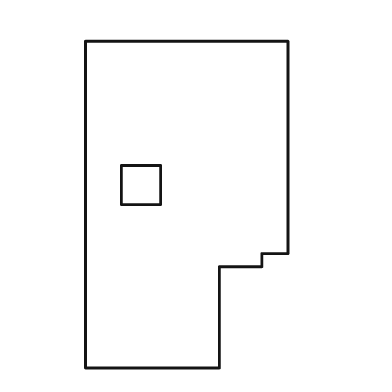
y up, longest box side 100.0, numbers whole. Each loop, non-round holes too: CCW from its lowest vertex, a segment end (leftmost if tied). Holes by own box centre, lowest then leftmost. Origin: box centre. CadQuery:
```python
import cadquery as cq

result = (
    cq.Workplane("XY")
    .moveTo(-31.0, -50.0)
    .lineTo(10.0, -50.0)
    .lineTo(10.0, -19.0)
    .lineTo(23.0, -19.0)
    .lineTo(23.0, -15.0)
    .lineTo(31.0, -15.0)
    .lineTo(31.0, 50.0)
    .lineTo(-31.0, 50.0)
    .close()
    .moveTo(-20.0, 0.0)
    .lineTo(-8.0, 0.0)
    .lineTo(-8.0, 12.0)
    .lineTo(-20.0, 12.0)
    .close()
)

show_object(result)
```